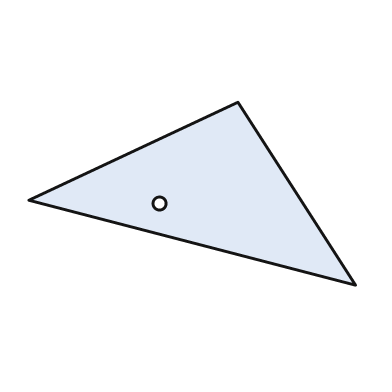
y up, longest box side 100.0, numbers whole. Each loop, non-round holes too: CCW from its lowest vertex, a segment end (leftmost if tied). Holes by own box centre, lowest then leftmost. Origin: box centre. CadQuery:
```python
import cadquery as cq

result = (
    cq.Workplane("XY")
    .moveTo(50.0, -28.0)
    .lineTo(14.0, 28.0)
    .lineTo(-50.0, -2.0)
    .close()
    .moveTo(-10.0, -3.0)
    .circle(2.0)
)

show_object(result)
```